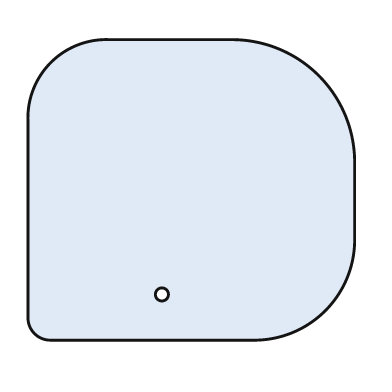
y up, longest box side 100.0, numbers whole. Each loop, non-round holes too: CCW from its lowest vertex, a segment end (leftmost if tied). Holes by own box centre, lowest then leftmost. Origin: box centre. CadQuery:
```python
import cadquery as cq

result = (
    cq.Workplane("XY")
    .moveTo(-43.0, -46.0)
    .lineTo(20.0, -46.0)
    .threePointArc((41.0, -37.0), (50.0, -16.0))
    .lineTo(50.0, 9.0)
    .threePointArc((39.0, 35.0), (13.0, 46.0))
    .lineTo(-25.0, 46.0)
    .threePointArc((-43.0, 39.0), (-50.0, 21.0))
    .lineTo(-50.0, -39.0)
    .threePointArc((-48.0, -44.0), (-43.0, -46.0))
    .close()
    .moveTo(-9.0, -32.0)
    .circle(2.0)
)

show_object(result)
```